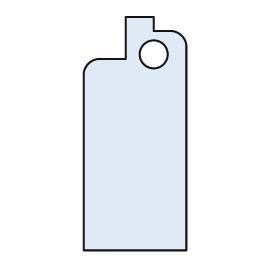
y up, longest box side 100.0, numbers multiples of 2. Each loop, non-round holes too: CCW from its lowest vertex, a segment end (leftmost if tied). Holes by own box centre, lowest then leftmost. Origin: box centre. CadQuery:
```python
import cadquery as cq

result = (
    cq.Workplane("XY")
    .moveTo(-22.0, -50.0)
    .lineTo(22.0, -50.0)
    .lineTo(22.0, 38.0)
    .threePointArc((20.0, 42.0), (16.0, 44.0))
    .lineTo(8.0, 44.0)
    .lineTo(8.0, 50.0)
    .lineTo(-4.0, 50.0)
    .lineTo(-4.0, 32.0)
    .lineTo(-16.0, 32.0)
    .threePointArc((-20.0, 30.0), (-22.0, 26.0))
    .close()
    .moveTo(8.0, 34.0)
    .circle(6.0)
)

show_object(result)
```